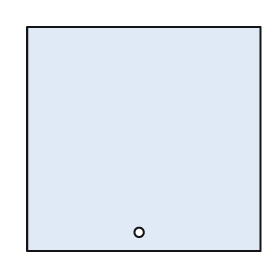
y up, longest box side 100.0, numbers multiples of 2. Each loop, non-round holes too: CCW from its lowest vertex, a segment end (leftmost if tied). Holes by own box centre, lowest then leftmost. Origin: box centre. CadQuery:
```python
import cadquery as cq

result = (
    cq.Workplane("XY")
    .moveTo(-50.0, -48.0)
    .lineTo(50.0, -48.0)
    .lineTo(50.0, 48.0)
    .lineTo(-50.0, 48.0)
    .close()
    .moveTo(-2.0, -40.0)
    .circle(2.0)
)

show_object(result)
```